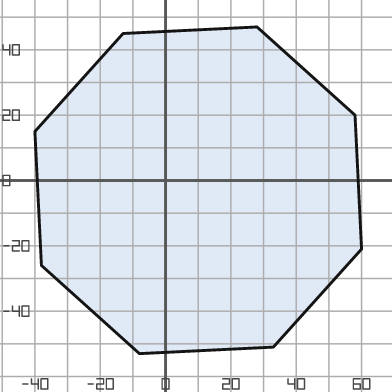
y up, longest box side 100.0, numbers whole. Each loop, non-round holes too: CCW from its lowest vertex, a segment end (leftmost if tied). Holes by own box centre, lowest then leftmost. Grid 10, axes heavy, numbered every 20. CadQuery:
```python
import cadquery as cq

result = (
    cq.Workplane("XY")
    .moveTo(-8.0, -53.0)
    .lineTo(33.0, -51.0)
    .lineTo(60.0, -21.0)
    .lineTo(58.0, 20.0)
    .lineTo(28.0, 47.0)
    .lineTo(-13.0, 45.0)
    .lineTo(-40.0, 15.0)
    .lineTo(-38.0, -26.0)
    .close()
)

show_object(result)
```